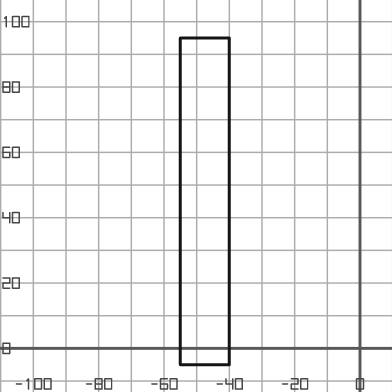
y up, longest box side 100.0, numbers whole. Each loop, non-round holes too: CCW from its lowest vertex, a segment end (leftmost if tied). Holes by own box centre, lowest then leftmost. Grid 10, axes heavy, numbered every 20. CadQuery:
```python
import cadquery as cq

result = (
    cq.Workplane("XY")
    .moveTo(-55.0, -5.0)
    .lineTo(-40.0, -5.0)
    .lineTo(-40.0, 95.0)
    .lineTo(-55.0, 95.0)
    .close()
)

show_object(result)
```